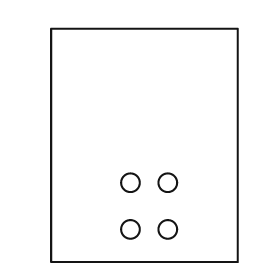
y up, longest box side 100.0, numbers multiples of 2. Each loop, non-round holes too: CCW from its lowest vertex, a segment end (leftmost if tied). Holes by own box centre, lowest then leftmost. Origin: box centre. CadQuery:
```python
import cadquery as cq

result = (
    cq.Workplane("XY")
    .moveTo(-40.0, -50.0)
    .lineTo(40.0, -50.0)
    .lineTo(40.0, 50.0)
    .lineTo(-40.0, 50.0)
    .close()
    .moveTo(-6.0, -36.0)
    .circle(4.0)
    .moveTo(10.0, -36.0)
    .circle(4.0)
    .moveTo(-6.0, -16.0)
    .circle(4.0)
    .moveTo(10.0, -16.0)
    .circle(4.0)
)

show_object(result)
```